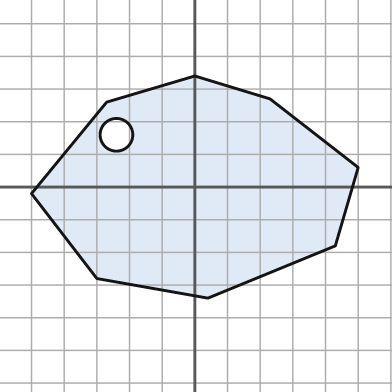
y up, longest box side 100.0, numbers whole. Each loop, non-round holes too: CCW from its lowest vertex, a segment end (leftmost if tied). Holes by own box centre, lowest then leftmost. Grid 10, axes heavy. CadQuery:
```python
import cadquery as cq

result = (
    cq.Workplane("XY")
    .moveTo(4.0, -34.0)
    .lineTo(43.0, -18.0)
    .lineTo(50.0, 6.0)
    .lineTo(23.0, 27.0)
    .lineTo(0.0, 34.0)
    .lineTo(-27.0, 26.0)
    .lineTo(-50.0, -2.0)
    .lineTo(-30.0, -28.0)
    .close()
    .moveTo(-24.0, 16.0)
    .circle(5.0)
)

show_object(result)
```